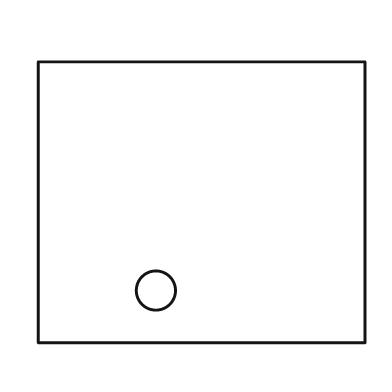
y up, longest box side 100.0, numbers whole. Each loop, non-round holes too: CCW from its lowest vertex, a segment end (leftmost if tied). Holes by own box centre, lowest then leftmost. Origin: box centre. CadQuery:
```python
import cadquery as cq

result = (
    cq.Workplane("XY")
    .moveTo(-50.0, -43.0)
    .lineTo(50.0, -43.0)
    .lineTo(50.0, 43.0)
    .lineTo(-50.0, 43.0)
    .close()
    .moveTo(-14.0, -27.0)
    .circle(6.0)
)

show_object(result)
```